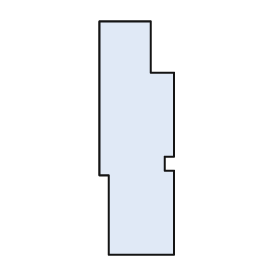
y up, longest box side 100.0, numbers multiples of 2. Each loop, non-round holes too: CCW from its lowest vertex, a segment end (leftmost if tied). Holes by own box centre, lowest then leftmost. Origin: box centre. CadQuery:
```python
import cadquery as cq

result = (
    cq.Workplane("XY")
    .moveTo(-12.0, -50.0)
    .lineTo(16.0, -50.0)
    .lineTo(16.0, -14.0)
    .lineTo(12.0, -14.0)
    .lineTo(12.0, -8.0)
    .lineTo(16.0, -8.0)
    .lineTo(16.0, 28.0)
    .lineTo(6.0, 28.0)
    .lineTo(6.0, 50.0)
    .lineTo(-16.0, 50.0)
    .lineTo(-16.0, -16.0)
    .lineTo(-12.0, -16.0)
    .close()
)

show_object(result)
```